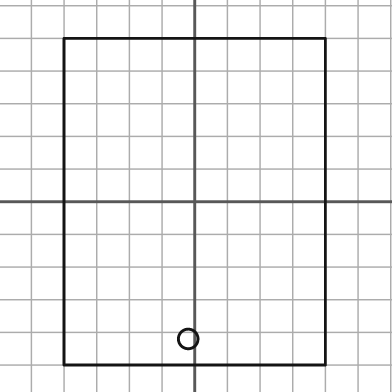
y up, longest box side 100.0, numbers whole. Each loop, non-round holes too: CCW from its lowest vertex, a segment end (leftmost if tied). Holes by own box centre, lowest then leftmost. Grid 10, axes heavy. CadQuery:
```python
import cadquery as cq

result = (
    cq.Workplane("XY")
    .moveTo(-40.0, -50.0)
    .lineTo(40.0, -50.0)
    .lineTo(40.0, 50.0)
    .lineTo(-40.0, 50.0)
    .close()
    .moveTo(-2.0, -42.0)
    .circle(3.0)
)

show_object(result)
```